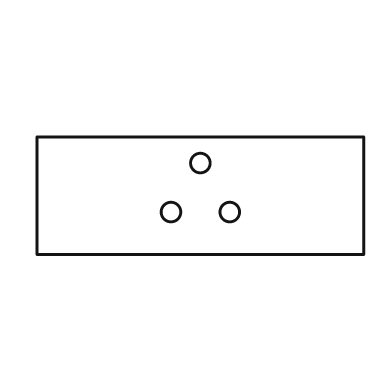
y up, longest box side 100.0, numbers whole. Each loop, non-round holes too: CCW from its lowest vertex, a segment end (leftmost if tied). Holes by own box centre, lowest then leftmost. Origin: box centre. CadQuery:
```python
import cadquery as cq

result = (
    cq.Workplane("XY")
    .moveTo(-50.0, -18.0)
    .lineTo(50.0, -18.0)
    .lineTo(50.0, 18.0)
    .lineTo(-50.0, 18.0)
    .close()
    .moveTo(-9.0, -5.0)
    .circle(3.0)
    .moveTo(9.0, -5.0)
    .circle(3.0)
    .moveTo(0.0, 10.0)
    .circle(3.0)
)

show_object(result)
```